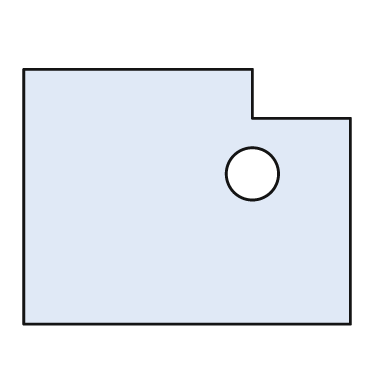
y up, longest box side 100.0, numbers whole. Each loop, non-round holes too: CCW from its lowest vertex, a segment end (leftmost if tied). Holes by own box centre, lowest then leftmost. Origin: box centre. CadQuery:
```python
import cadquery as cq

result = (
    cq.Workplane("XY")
    .moveTo(-50.0, -39.0)
    .lineTo(50.0, -39.0)
    .lineTo(50.0, 24.0)
    .lineTo(20.0, 24.0)
    .lineTo(20.0, 39.0)
    .lineTo(-50.0, 39.0)
    .close()
    .moveTo(20.0, 7.0)
    .circle(8.0)
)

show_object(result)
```